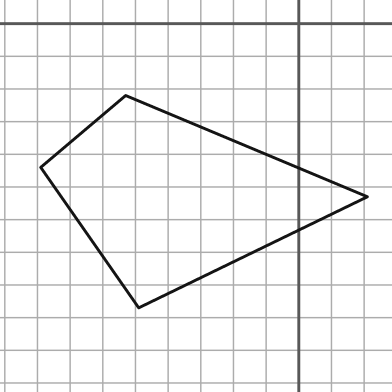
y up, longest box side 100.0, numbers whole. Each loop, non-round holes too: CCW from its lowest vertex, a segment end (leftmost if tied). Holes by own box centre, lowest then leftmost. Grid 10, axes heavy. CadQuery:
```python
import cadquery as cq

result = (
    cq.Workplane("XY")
    .moveTo(-49.0, -87.0)
    .lineTo(21.0, -53.0)
    .lineTo(-53.0, -22.0)
    .lineTo(-79.0, -44.0)
    .close()
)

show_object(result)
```